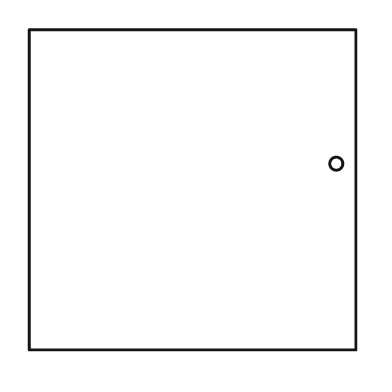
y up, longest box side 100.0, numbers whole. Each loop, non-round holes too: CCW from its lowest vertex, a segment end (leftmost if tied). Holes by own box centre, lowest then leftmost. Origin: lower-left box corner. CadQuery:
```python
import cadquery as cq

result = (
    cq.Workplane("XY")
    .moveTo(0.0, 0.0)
    .lineTo(100.0, 0.0)
    .lineTo(100.0, 98.0)
    .lineTo(0.0, 98.0)
    .close()
    .moveTo(94.0, 57.0)
    .circle(2.0)
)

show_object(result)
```